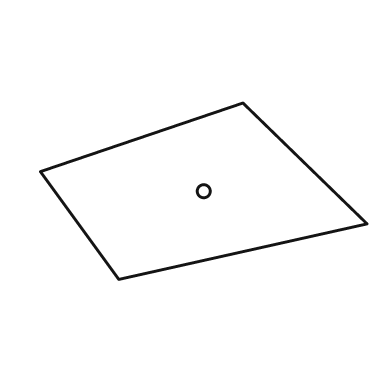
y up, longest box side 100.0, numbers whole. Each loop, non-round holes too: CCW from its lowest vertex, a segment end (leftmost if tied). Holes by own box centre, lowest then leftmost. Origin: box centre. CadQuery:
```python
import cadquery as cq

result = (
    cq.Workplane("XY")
    .moveTo(-26.0, -27.0)
    .lineTo(50.0, -10.0)
    .lineTo(12.0, 27.0)
    .lineTo(-50.0, 6.0)
    .close()
    .moveTo(0.0, 0.0)
    .circle(2.0)
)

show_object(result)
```